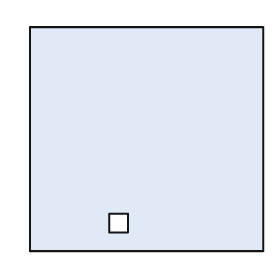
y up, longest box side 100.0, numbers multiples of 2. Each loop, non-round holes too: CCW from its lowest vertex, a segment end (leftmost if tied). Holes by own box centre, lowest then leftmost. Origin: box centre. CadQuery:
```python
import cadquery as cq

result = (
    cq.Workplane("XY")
    .moveTo(-50.0, -48.0)
    .lineTo(50.0, -48.0)
    .lineTo(50.0, 48.0)
    .lineTo(-50.0, 48.0)
    .close()
    .moveTo(-16.0, -40.0)
    .lineTo(-8.0, -40.0)
    .lineTo(-8.0, -32.0)
    .lineTo(-16.0, -32.0)
    .close()
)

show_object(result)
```